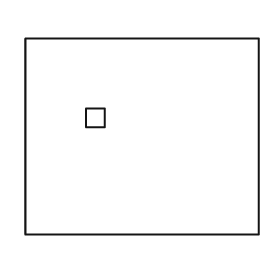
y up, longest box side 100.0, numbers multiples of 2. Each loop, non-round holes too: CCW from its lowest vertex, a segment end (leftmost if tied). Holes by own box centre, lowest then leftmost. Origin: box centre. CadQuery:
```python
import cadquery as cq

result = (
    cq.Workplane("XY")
    .moveTo(-50.0, -42.0)
    .lineTo(50.0, -42.0)
    .lineTo(50.0, 42.0)
    .lineTo(-50.0, 42.0)
    .close()
    .moveTo(-24.0, 4.0)
    .lineTo(-16.0, 4.0)
    .lineTo(-16.0, 12.0)
    .lineTo(-24.0, 12.0)
    .close()
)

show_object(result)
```